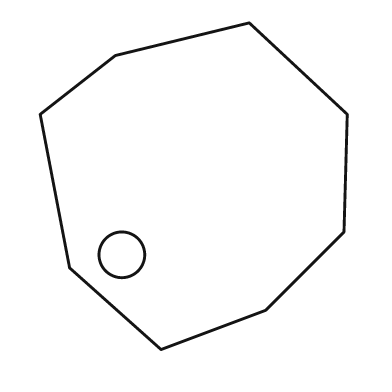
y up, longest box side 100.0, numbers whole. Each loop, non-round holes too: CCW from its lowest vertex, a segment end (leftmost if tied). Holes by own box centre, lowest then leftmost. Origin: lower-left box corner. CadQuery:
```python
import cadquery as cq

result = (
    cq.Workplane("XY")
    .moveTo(37.0, 0.0)
    .lineTo(69.0, 12.0)
    .lineTo(93.0, 36.0)
    .lineTo(94.0, 72.0)
    .lineTo(64.0, 100.0)
    .lineTo(23.0, 90.0)
    .lineTo(0.0, 72.0)
    .lineTo(9.0, 25.0)
    .close()
    .moveTo(25.0, 29.0)
    .circle(7.0)
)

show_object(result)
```